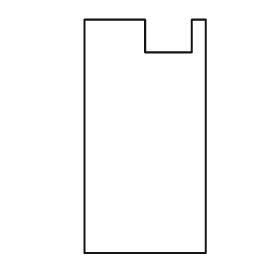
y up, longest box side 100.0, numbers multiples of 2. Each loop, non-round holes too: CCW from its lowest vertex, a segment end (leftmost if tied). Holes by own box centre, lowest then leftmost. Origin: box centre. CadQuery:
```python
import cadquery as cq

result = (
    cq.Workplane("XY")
    .moveTo(-26.0, -50.0)
    .lineTo(26.0, -50.0)
    .lineTo(26.0, 50.0)
    .lineTo(20.0, 50.0)
    .lineTo(20.0, 36.0)
    .lineTo(0.0, 36.0)
    .lineTo(0.0, 50.0)
    .lineTo(-26.0, 50.0)
    .close()
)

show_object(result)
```